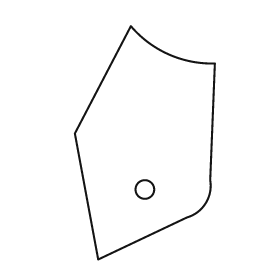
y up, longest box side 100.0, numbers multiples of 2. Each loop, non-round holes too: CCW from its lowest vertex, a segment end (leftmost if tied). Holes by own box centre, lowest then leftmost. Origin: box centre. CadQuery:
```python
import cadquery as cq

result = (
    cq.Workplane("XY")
    .moveTo(-20.0, -50.0)
    .lineTo(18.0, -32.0)
    .threePointArc((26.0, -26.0), (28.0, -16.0))
    .lineTo(30.0, 34.0)
    .threePointArc((10.0, 38.0), (-6.0, 50.0))
    .lineTo(-30.0, 4.0)
    .close()
    .moveTo(0.0, -20.0)
    .circle(4.0)
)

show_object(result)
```